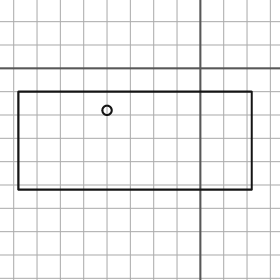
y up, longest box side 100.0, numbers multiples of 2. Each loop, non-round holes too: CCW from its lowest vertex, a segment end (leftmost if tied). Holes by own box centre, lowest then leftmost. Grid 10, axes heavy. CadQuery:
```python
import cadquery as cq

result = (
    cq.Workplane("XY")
    .moveTo(-78.0, -52.0)
    .lineTo(22.0, -52.0)
    .lineTo(22.0, -10.0)
    .lineTo(-78.0, -10.0)
    .close()
    .moveTo(-40.0, -18.0)
    .circle(2.0)
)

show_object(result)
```